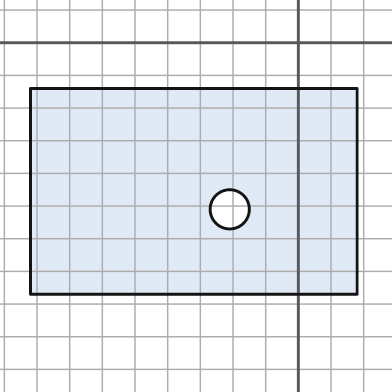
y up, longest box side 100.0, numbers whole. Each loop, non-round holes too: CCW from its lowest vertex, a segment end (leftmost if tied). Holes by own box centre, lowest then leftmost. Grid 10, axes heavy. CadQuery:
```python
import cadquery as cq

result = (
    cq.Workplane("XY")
    .moveTo(-82.0, -77.0)
    .lineTo(18.0, -77.0)
    .lineTo(18.0, -14.0)
    .lineTo(-82.0, -14.0)
    .close()
    .moveTo(-21.0, -51.0)
    .circle(6.0)
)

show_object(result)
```